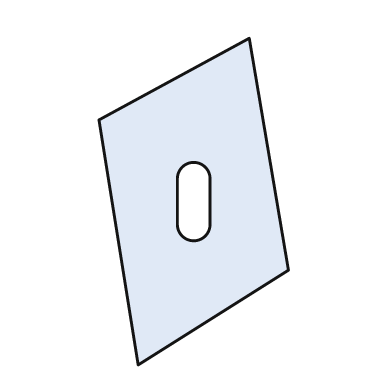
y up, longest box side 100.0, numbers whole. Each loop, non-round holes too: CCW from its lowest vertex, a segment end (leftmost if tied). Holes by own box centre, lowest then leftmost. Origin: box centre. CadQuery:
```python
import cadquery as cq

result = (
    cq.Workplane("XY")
    .moveTo(-17.0, -50.0)
    .lineTo(29.0, -21.0)
    .lineTo(17.0, 50.0)
    .lineTo(-29.0, 25.0)
    .close()
    .moveTo(-5.0, -7.0)
    .threePointArc((0.0, -12.0), (5.0, -7.0))
    .lineTo(5.0, 7.0)
    .threePointArc((0.0, 12.0), (-5.0, 7.0))
    .close()
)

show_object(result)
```